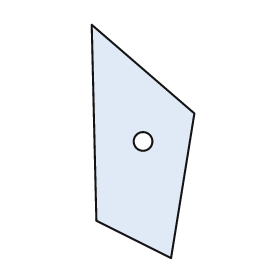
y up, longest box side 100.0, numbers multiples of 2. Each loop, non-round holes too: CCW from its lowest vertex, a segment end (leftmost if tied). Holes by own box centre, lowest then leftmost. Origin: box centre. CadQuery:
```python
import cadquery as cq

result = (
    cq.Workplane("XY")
    .moveTo(12.0, -50.0)
    .lineTo(22.0, 12.0)
    .lineTo(-22.0, 50.0)
    .lineTo(-20.0, -34.0)
    .close()
    .moveTo(0.0, 0.0)
    .circle(4.0)
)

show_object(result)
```